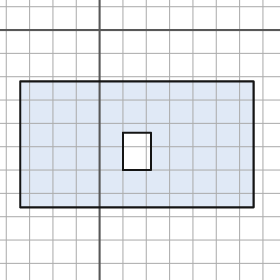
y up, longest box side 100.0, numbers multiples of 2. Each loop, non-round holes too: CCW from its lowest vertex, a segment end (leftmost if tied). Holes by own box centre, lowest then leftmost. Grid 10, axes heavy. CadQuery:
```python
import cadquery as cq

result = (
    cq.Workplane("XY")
    .moveTo(-34.0, -76.0)
    .lineTo(66.0, -76.0)
    .lineTo(66.0, -22.0)
    .lineTo(-34.0, -22.0)
    .close()
    .moveTo(10.0, -60.0)
    .lineTo(22.0, -60.0)
    .lineTo(22.0, -44.0)
    .lineTo(10.0, -44.0)
    .close()
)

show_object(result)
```